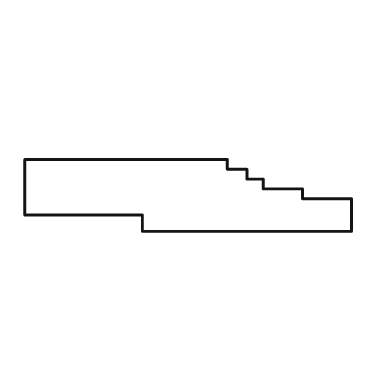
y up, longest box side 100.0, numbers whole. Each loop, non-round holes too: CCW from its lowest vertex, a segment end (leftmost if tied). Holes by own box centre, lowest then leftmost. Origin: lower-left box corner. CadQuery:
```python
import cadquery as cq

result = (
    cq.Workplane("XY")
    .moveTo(36.0, 0.0)
    .lineTo(100.0, 0.0)
    .lineTo(100.0, 10.0)
    .lineTo(85.0, 10.0)
    .lineTo(85.0, 13.0)
    .lineTo(73.0, 13.0)
    .lineTo(73.0, 16.0)
    .lineTo(68.0, 16.0)
    .lineTo(68.0, 19.0)
    .lineTo(62.0, 19.0)
    .lineTo(62.0, 22.0)
    .lineTo(0.0, 22.0)
    .lineTo(0.0, 5.0)
    .lineTo(36.0, 5.0)
    .close()
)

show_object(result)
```